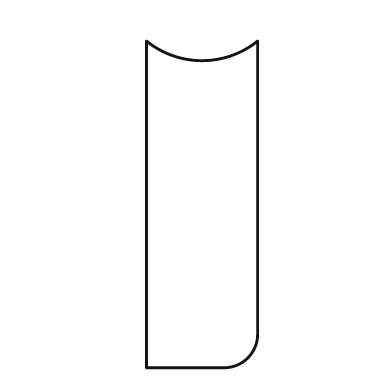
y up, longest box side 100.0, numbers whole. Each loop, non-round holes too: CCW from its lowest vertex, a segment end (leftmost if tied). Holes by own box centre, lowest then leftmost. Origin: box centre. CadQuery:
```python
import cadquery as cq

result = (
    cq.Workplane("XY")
    .moveTo(-17.0, -50.0)
    .lineTo(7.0, -50.0)
    .threePointArc((14.0, -47.0), (17.0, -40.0))
    .lineTo(17.0, 50.0)
    .threePointArc((0.0, 44.0), (-17.0, 50.0))
    .close()
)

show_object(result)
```